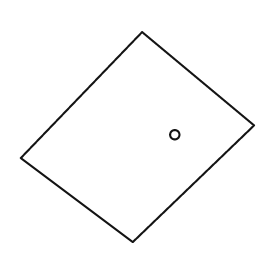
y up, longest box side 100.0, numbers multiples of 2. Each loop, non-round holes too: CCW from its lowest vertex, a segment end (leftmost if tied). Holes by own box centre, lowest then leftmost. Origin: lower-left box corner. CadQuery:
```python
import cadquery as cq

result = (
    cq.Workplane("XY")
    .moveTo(48.0, 0.0)
    .lineTo(100.0, 50.0)
    .lineTo(52.0, 90.0)
    .lineTo(0.0, 36.0)
    .close()
    .moveTo(66.0, 46.0)
    .circle(2.0)
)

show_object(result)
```